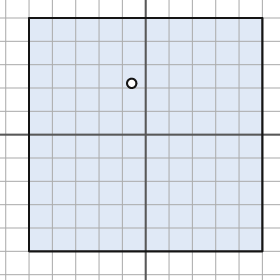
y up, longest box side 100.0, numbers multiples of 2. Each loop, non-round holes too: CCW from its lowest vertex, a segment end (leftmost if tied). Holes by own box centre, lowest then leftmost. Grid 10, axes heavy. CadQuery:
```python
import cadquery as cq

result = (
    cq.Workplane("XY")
    .moveTo(-50.0, -50.0)
    .lineTo(50.0, -50.0)
    .lineTo(50.0, 50.0)
    .lineTo(-50.0, 50.0)
    .close()
    .moveTo(-6.0, 22.0)
    .circle(2.0)
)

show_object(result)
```